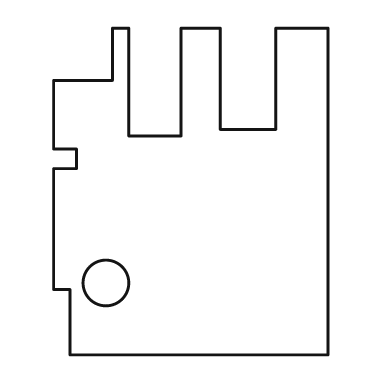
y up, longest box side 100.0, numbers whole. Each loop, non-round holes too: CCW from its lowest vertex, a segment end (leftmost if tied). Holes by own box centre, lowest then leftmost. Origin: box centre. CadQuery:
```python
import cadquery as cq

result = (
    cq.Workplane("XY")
    .moveTo(-37.0, -50.0)
    .lineTo(42.0, -50.0)
    .lineTo(42.0, 50.0)
    .lineTo(26.0, 50.0)
    .lineTo(26.0, 19.0)
    .lineTo(9.0, 19.0)
    .lineTo(9.0, 50.0)
    .lineTo(-3.0, 50.0)
    .lineTo(-3.0, 17.0)
    .lineTo(-19.0, 17.0)
    .lineTo(-19.0, 50.0)
    .lineTo(-24.0, 50.0)
    .lineTo(-24.0, 34.0)
    .lineTo(-42.0, 34.0)
    .lineTo(-42.0, 13.0)
    .lineTo(-35.0, 13.0)
    .lineTo(-35.0, 7.0)
    .lineTo(-42.0, 7.0)
    .lineTo(-42.0, -30.0)
    .lineTo(-37.0, -30.0)
    .close()
    .moveTo(-26.0, -28.0)
    .circle(7.0)
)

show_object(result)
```